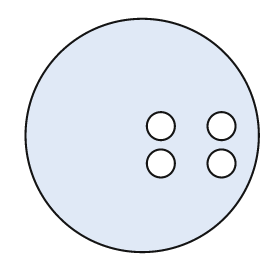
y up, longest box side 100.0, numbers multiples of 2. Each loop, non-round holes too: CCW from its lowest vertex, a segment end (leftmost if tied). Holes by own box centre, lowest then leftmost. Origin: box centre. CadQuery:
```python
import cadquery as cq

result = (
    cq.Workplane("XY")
    .moveTo(0.0, 0.0)
    .circle(50.0)
    .moveTo(8.0, -12.0)
    .circle(6.0)
    .moveTo(34.0, -12.0)
    .circle(6.0)
    .moveTo(8.0, 4.0)
    .circle(6.0)
    .moveTo(34.0, 4.0)
    .circle(6.0)
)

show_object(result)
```